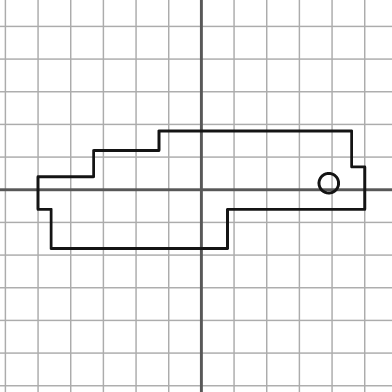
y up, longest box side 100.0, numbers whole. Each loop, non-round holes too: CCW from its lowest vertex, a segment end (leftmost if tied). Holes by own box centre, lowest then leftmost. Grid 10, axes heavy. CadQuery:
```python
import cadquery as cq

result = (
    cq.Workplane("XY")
    .moveTo(-46.0, -18.0)
    .lineTo(8.0, -18.0)
    .lineTo(8.0, -6.0)
    .lineTo(50.0, -6.0)
    .lineTo(50.0, 7.0)
    .lineTo(46.0, 7.0)
    .lineTo(46.0, 18.0)
    .lineTo(-13.0, 18.0)
    .lineTo(-13.0, 12.0)
    .lineTo(-33.0, 12.0)
    .lineTo(-33.0, 4.0)
    .lineTo(-50.0, 4.0)
    .lineTo(-50.0, -6.0)
    .lineTo(-46.0, -6.0)
    .close()
    .moveTo(39.0, 2.0)
    .circle(3.0)
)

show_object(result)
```